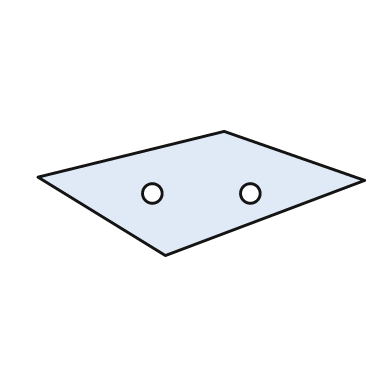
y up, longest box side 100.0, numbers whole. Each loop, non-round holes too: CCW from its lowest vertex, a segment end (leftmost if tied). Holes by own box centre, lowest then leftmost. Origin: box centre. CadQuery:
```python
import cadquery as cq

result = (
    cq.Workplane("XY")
    .moveTo(-11.0, -19.0)
    .lineTo(50.0, 4.0)
    .lineTo(7.0, 19.0)
    .lineTo(-50.0, 5.0)
    .close()
    .moveTo(-15.0, 0.0)
    .circle(3.0)
    .moveTo(15.0, 0.0)
    .circle(3.0)
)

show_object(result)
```